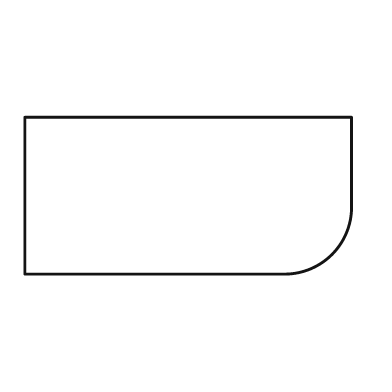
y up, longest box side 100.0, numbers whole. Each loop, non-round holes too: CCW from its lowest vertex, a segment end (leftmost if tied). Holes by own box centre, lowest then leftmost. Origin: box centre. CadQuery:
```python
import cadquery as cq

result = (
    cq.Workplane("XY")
    .moveTo(-50.0, -24.0)
    .lineTo(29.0, -24.0)
    .threePointArc((44.0, -18.0), (50.0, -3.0))
    .lineTo(50.0, 24.0)
    .lineTo(-50.0, 24.0)
    .close()
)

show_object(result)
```